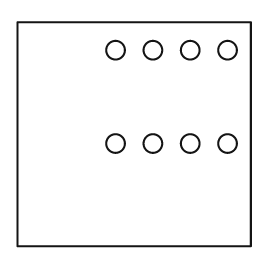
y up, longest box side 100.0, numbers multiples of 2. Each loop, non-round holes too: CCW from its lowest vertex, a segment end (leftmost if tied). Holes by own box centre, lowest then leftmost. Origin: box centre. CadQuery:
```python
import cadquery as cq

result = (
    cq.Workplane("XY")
    .moveTo(-50.0, -48.0)
    .lineTo(50.0, -48.0)
    .lineTo(50.0, 48.0)
    .lineTo(-50.0, 48.0)
    .close()
    .moveTo(-8.0, -4.0)
    .circle(4.0)
    .moveTo(8.0, -4.0)
    .circle(4.0)
    .moveTo(24.0, -4.0)
    .circle(4.0)
    .moveTo(40.0, -4.0)
    .circle(4.0)
    .moveTo(-8.0, 36.0)
    .circle(4.0)
    .moveTo(8.0, 36.0)
    .circle(4.0)
    .moveTo(24.0, 36.0)
    .circle(4.0)
    .moveTo(40.0, 36.0)
    .circle(4.0)
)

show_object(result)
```